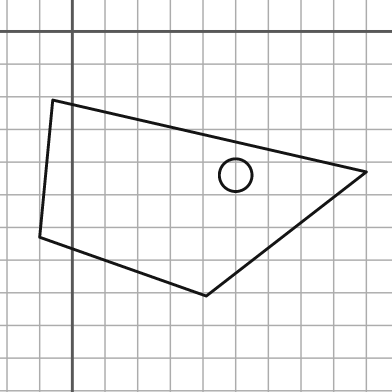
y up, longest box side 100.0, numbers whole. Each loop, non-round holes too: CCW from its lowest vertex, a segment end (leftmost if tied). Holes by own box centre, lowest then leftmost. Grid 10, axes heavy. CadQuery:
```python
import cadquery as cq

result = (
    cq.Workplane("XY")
    .moveTo(41.0, -81.0)
    .lineTo(90.0, -43.0)
    .lineTo(-6.0, -21.0)
    .lineTo(-10.0, -63.0)
    .close()
    .moveTo(50.0, -44.0)
    .circle(5.0)
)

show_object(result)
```